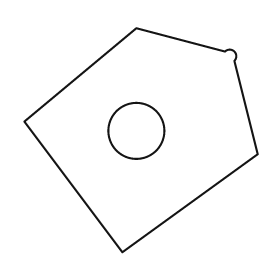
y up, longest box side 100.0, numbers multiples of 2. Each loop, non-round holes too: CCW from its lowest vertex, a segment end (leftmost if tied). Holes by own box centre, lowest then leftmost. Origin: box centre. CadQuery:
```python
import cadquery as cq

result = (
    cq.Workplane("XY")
    .moveTo(-8.0, -48.0)
    .lineTo(50.0, -6.0)
    .lineTo(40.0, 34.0)
    .threePointArc((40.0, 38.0), (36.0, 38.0))
    .lineTo(-2.0, 48.0)
    .lineTo(-50.0, 8.0)
    .close()
    .moveTo(-2.0, 4.0)
    .circle(12.0)
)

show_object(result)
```